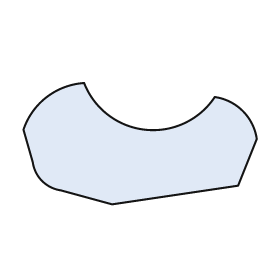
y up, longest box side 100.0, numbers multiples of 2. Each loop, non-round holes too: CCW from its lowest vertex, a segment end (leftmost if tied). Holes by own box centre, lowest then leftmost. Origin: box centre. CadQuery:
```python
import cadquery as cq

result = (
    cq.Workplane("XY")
    .moveTo(-12.0, -26.0)
    .lineTo(42.0, -18.0)
    .lineTo(50.0, 2.0)
    .threePointArc((44.0, 14.0), (32.0, 20.0))
    .threePointArc((2.0, 6.0), (-24.0, 26.0))
    .threePointArc((-40.0, 20.0), (-50.0, 6.0))
    .lineTo(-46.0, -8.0)
    .threePointArc((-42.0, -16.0), (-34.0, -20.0))
    .close()
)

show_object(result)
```